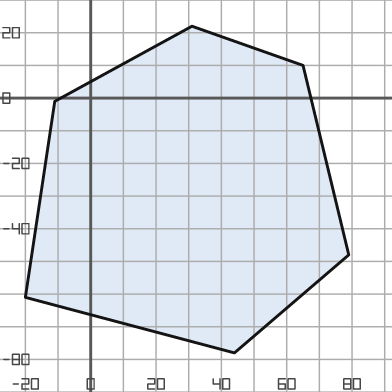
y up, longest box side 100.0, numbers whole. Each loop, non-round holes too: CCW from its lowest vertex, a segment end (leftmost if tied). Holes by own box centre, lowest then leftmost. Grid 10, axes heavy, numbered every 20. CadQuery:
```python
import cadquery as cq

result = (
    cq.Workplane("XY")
    .moveTo(44.0, -78.0)
    .lineTo(79.0, -48.0)
    .lineTo(65.0, 10.0)
    .lineTo(31.0, 22.0)
    .lineTo(-11.0, -1.0)
    .lineTo(-20.0, -61.0)
    .close()
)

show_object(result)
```